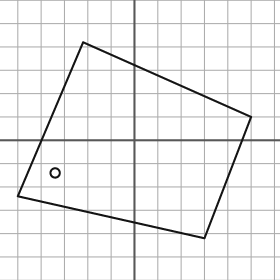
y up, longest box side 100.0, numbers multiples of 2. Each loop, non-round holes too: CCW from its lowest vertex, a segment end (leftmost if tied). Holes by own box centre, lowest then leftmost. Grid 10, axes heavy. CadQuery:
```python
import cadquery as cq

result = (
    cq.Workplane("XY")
    .moveTo(30.0, -42.0)
    .lineTo(50.0, 10.0)
    .lineTo(-22.0, 42.0)
    .lineTo(-50.0, -24.0)
    .close()
    .moveTo(-34.0, -14.0)
    .circle(2.0)
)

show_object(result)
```